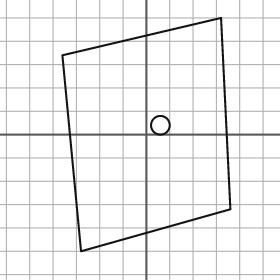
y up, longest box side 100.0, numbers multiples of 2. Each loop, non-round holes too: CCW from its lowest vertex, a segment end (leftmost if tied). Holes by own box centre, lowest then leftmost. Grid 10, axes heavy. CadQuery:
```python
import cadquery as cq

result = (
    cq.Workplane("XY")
    .moveTo(-28.0, -50.0)
    .lineTo(36.0, -32.0)
    .lineTo(32.0, 50.0)
    .lineTo(-36.0, 34.0)
    .close()
    .moveTo(6.0, 4.0)
    .circle(4.0)
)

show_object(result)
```